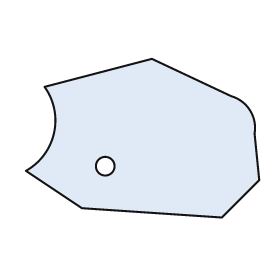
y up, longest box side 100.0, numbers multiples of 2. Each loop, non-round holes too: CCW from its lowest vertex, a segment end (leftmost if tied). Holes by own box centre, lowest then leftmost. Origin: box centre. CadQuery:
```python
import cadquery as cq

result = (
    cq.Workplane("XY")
    .moveTo(34.0, -34.0)
    .lineTo(50.0, -18.0)
    .lineTo(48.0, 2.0)
    .threePointArc((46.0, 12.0), (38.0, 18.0))
    .lineTo(4.0, 34.0)
    .lineTo(-42.0, 22.0)
    .threePointArc((-38.0, 2.0), (-50.0, -14.0))
    .lineTo(-26.0, -30.0)
    .close()
    .moveTo(-16.0, -12.0)
    .circle(4.0)
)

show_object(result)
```